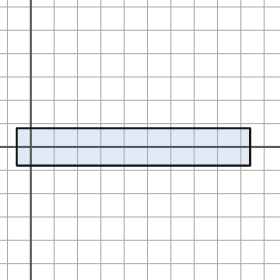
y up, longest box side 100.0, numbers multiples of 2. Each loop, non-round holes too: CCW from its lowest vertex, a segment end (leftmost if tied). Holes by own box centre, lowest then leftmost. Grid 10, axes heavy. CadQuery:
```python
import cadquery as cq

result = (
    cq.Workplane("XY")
    .moveTo(-6.0, -8.0)
    .lineTo(94.0, -8.0)
    .lineTo(94.0, 8.0)
    .lineTo(-6.0, 8.0)
    .close()
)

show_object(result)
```